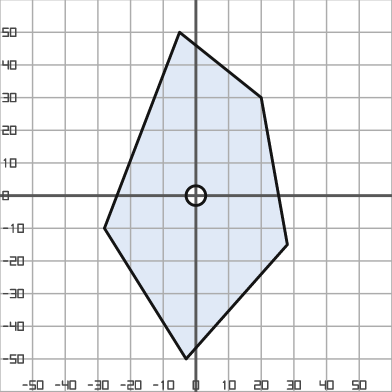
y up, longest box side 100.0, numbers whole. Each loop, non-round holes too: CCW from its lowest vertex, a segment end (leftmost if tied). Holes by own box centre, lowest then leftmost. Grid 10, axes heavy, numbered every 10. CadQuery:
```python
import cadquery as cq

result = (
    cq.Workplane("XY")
    .moveTo(-3.0, -50.0)
    .lineTo(28.0, -15.0)
    .lineTo(20.0, 30.0)
    .lineTo(-5.0, 50.0)
    .lineTo(-28.0, -10.0)
    .close()
    .moveTo(0.0, 0.0)
    .circle(3.0)
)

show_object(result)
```